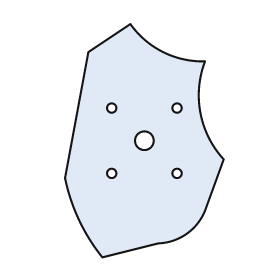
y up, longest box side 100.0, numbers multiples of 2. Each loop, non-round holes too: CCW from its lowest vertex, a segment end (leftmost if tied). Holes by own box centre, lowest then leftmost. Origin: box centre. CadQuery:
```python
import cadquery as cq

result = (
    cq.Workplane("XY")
    .moveTo(-18.0, -50.0)
    .lineTo(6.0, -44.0)
    .threePointArc((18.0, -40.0), (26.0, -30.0))
    .lineTo(34.0, -8.0)
    .threePointArc((24.0, 12.0), (26.0, 34.0))
    .threePointArc((8.0, 38.0), (-6.0, 50.0))
    .lineTo(-24.0, 38.0)
    .lineTo(-34.0, -16.0)
    .threePointArc((-28.0, -34.0), (-18.0, -50.0))
    .close()
    .moveTo(-14.0, -14.0)
    .circle(2.0)
    .moveTo(14.0, -14.0)
    .circle(2.0)
    .moveTo(0.0, 0.0)
    .circle(4.0)
    .moveTo(-14.0, 14.0)
    .circle(2.0)
    .moveTo(14.0, 14.0)
    .circle(2.0)
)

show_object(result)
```